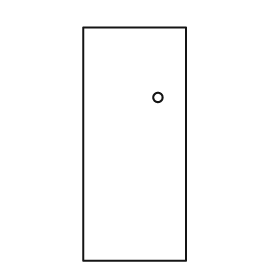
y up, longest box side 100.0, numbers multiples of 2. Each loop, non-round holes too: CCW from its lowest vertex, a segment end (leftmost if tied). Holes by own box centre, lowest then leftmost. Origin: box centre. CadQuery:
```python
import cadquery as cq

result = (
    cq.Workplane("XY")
    .moveTo(-22.0, -50.0)
    .lineTo(22.0, -50.0)
    .lineTo(22.0, 50.0)
    .lineTo(-22.0, 50.0)
    .close()
    .moveTo(10.0, 20.0)
    .circle(2.0)
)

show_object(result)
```